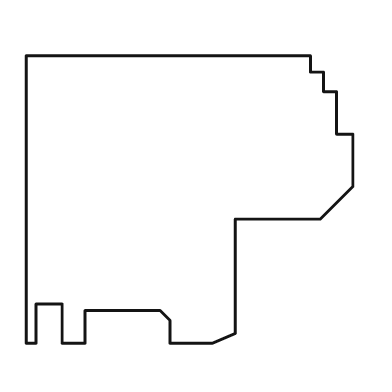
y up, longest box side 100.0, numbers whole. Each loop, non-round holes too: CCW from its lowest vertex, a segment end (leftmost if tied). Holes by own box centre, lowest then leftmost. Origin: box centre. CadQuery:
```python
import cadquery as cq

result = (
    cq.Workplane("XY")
    .moveTo(-50.0, -44.0)
    .lineTo(-47.0, -44.0)
    .lineTo(-47.0, -32.0)
    .lineTo(-39.0, -32.0)
    .lineTo(-39.0, -44.0)
    .lineTo(-32.0, -44.0)
    .lineTo(-32.0, -34.0)
    .lineTo(-9.0, -34.0)
    .lineTo(-6.0, -37.0)
    .lineTo(-6.0, -44.0)
    .lineTo(7.0, -44.0)
    .lineTo(14.0, -41.0)
    .lineTo(14.0, -6.0)
    .lineTo(40.0, -6.0)
    .lineTo(50.0, 4.0)
    .lineTo(50.0, 20.0)
    .lineTo(45.0, 20.0)
    .lineTo(45.0, 33.0)
    .lineTo(41.0, 33.0)
    .lineTo(41.0, 39.0)
    .lineTo(37.0, 39.0)
    .lineTo(37.0, 44.0)
    .lineTo(-50.0, 44.0)
    .close()
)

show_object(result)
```